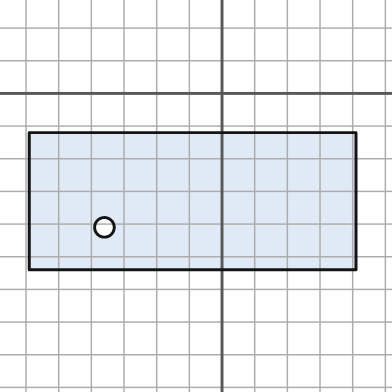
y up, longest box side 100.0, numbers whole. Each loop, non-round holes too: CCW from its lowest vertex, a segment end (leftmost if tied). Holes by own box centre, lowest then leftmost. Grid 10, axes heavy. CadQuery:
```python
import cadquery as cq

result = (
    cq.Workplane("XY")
    .moveTo(-59.0, -54.0)
    .lineTo(41.0, -54.0)
    .lineTo(41.0, -12.0)
    .lineTo(-59.0, -12.0)
    .close()
    .moveTo(-36.0, -41.0)
    .circle(3.0)
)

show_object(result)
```